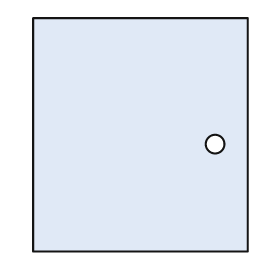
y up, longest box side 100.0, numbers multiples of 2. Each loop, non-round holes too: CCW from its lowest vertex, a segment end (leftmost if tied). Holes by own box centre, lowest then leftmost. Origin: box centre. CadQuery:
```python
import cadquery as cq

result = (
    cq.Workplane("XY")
    .moveTo(-46.0, -50.0)
    .lineTo(46.0, -50.0)
    .lineTo(46.0, 50.0)
    .lineTo(-46.0, 50.0)
    .close()
    .moveTo(32.0, -4.0)
    .circle(4.0)
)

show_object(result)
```